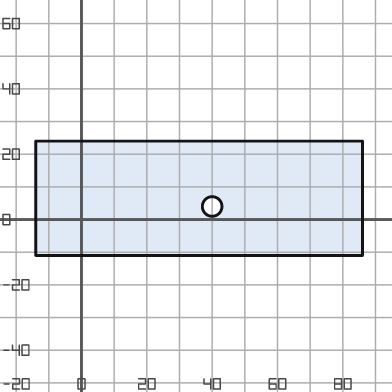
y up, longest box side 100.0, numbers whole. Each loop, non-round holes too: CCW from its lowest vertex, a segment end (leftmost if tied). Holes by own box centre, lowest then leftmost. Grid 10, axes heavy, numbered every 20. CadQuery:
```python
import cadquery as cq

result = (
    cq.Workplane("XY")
    .moveTo(-14.0, -11.0)
    .lineTo(86.0, -11.0)
    .lineTo(86.0, 24.0)
    .lineTo(-14.0, 24.0)
    .close()
    .moveTo(40.0, 4.0)
    .circle(3.0)
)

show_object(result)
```